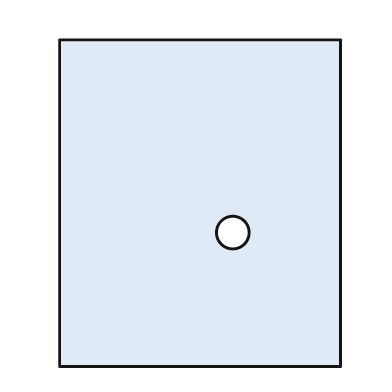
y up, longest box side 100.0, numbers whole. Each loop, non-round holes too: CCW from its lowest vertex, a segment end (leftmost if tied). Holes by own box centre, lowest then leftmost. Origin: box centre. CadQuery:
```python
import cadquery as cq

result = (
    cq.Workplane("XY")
    .moveTo(-43.0, -50.0)
    .lineTo(43.0, -50.0)
    .lineTo(43.0, 50.0)
    .lineTo(-43.0, 50.0)
    .close()
    .moveTo(10.0, -9.0)
    .circle(5.0)
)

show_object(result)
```